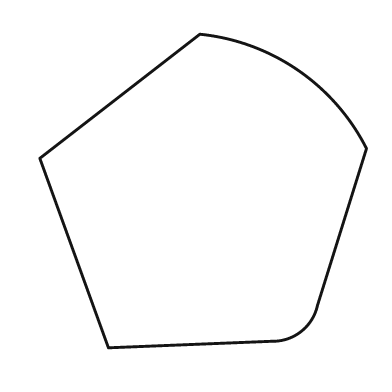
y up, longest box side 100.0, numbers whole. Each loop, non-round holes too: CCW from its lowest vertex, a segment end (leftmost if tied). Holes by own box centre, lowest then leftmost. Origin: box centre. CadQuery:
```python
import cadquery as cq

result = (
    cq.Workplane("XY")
    .moveTo(-29.0, -48.0)
    .lineTo(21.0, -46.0)
    .threePointArc((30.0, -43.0), (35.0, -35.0))
    .lineTo(50.0, 13.0)
    .threePointArc((29.0, 37.0), (-1.0, 48.0))
    .lineTo(-50.0, 10.0)
    .close()
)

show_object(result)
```